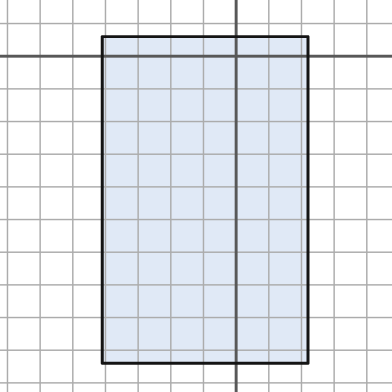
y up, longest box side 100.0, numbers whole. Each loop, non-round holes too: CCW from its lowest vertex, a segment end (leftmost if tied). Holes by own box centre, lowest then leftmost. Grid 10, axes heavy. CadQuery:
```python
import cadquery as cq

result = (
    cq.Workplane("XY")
    .moveTo(-41.0, -94.0)
    .lineTo(22.0, -94.0)
    .lineTo(22.0, 6.0)
    .lineTo(-41.0, 6.0)
    .close()
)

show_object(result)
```